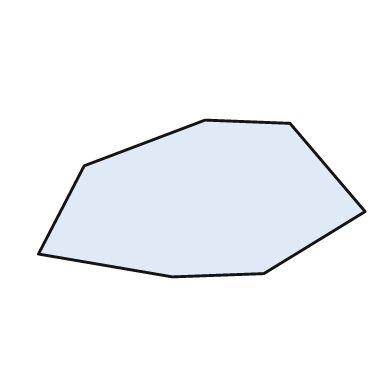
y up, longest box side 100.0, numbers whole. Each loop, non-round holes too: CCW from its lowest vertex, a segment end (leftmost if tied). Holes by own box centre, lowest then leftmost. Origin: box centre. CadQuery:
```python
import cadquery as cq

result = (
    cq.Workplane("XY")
    .moveTo(-9.0, -24.0)
    .lineTo(19.0, -23.0)
    .lineTo(50.0, -4.0)
    .lineTo(27.0, 23.0)
    .lineTo(1.0, 24.0)
    .lineTo(-36.0, 10.0)
    .lineTo(-50.0, -17.0)
    .close()
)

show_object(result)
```